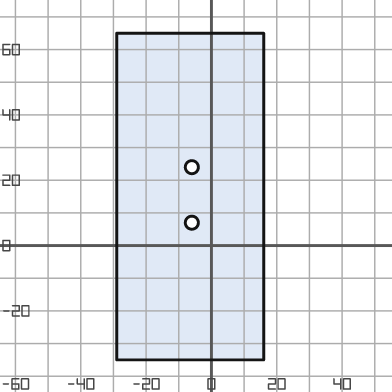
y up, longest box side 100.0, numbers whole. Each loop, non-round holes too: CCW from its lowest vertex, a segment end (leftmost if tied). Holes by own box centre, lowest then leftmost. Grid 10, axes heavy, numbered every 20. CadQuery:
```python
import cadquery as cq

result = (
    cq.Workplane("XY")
    .moveTo(-29.0, -35.0)
    .lineTo(16.0, -35.0)
    .lineTo(16.0, 65.0)
    .lineTo(-29.0, 65.0)
    .close()
    .moveTo(-6.0, 7.0)
    .circle(2.0)
    .moveTo(-6.0, 24.0)
    .circle(2.0)
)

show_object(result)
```